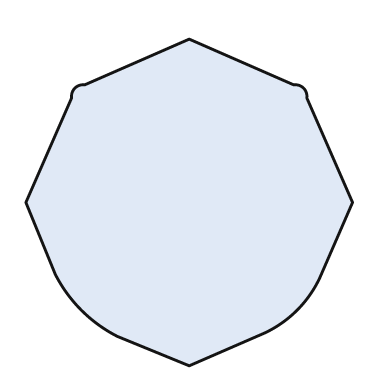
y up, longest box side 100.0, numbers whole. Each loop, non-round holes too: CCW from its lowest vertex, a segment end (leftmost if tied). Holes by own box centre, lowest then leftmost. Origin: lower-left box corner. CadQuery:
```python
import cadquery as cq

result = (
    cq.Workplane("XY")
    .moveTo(50.0, 0.0)
    .lineTo(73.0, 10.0)
    .threePointArc((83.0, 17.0), (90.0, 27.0))
    .lineTo(100.0, 50.0)
    .lineTo(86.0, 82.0)
    .threePointArc((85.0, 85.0), (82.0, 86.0))
    .lineTo(50.0, 100.0)
    .lineTo(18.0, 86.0)
    .threePointArc((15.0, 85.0), (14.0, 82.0))
    .lineTo(0.0, 50.0)
    .lineTo(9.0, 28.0)
    .threePointArc((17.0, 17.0), (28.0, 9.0))
    .close()
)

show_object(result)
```